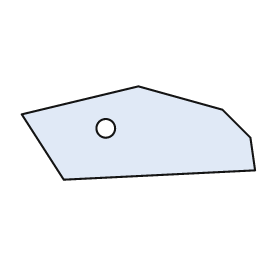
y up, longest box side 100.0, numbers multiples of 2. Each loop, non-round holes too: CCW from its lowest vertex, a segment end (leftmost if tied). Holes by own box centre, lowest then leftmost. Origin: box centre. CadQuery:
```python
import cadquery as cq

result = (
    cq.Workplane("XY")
    .moveTo(-32.0, -20.0)
    .lineTo(50.0, -16.0)
    .lineTo(48.0, -2.0)
    .lineTo(36.0, 10.0)
    .lineTo(0.0, 20.0)
    .lineTo(-50.0, 8.0)
    .close()
    .moveTo(-14.0, 2.0)
    .circle(4.0)
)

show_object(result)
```